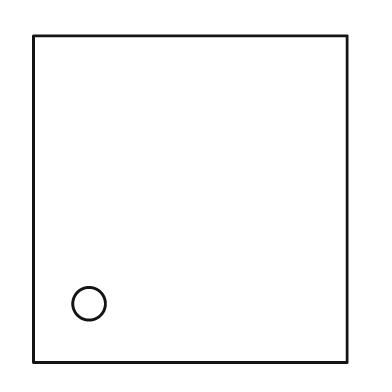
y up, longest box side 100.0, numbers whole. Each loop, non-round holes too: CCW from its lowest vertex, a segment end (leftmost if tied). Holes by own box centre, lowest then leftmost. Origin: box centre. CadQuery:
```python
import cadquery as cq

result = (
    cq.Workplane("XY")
    .moveTo(-48.0, -50.0)
    .lineTo(48.0, -50.0)
    .lineTo(48.0, 50.0)
    .lineTo(-48.0, 50.0)
    .close()
    .moveTo(-31.0, -32.0)
    .circle(5.0)
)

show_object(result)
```